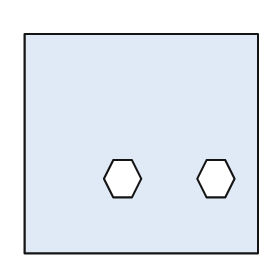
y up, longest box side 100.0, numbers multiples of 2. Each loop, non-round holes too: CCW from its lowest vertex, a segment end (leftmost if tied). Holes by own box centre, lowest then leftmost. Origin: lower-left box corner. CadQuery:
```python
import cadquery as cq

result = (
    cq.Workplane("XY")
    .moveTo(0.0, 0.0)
    .lineTo(100.0, 0.0)
    .lineTo(100.0, 94.0)
    .lineTo(0.0, 94.0)
    .close()
    .moveTo(38.0, 24.0)
    .lineTo(46.0, 24.0)
    .lineTo(50.0, 32.0)
    .lineTo(46.0, 40.0)
    .lineTo(38.0, 40.0)
    .lineTo(34.0, 32.0)
    .close()
    .moveTo(78.0, 24.0)
    .lineTo(86.0, 24.0)
    .lineTo(90.0, 32.0)
    .lineTo(86.0, 40.0)
    .lineTo(78.0, 40.0)
    .lineTo(74.0, 32.0)
    .close()
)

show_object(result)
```